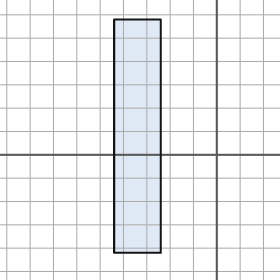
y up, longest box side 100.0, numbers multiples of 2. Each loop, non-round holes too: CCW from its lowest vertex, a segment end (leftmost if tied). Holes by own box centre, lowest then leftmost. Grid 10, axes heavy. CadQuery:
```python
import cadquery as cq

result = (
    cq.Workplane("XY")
    .moveTo(-44.0, -42.0)
    .lineTo(-24.0, -42.0)
    .lineTo(-24.0, 58.0)
    .lineTo(-44.0, 58.0)
    .close()
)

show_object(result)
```